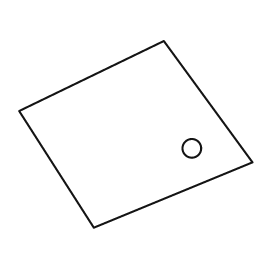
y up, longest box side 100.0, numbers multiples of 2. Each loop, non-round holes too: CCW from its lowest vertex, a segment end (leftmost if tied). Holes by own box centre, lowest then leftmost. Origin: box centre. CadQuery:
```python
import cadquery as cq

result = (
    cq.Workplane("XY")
    .moveTo(-18.0, -40.0)
    .lineTo(50.0, -12.0)
    .lineTo(12.0, 40.0)
    .lineTo(-50.0, 10.0)
    .close()
    .moveTo(24.0, -6.0)
    .circle(4.0)
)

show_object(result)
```